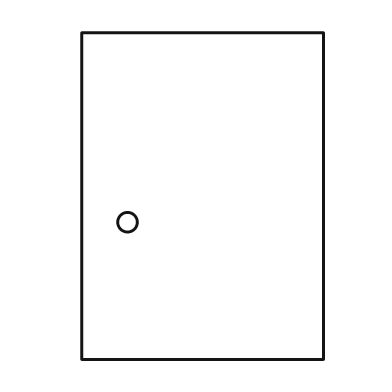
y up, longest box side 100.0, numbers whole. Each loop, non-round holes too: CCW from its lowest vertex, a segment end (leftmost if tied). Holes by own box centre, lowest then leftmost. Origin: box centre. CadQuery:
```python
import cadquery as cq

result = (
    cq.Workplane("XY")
    .moveTo(-37.0, -50.0)
    .lineTo(37.0, -50.0)
    .lineTo(37.0, 50.0)
    .lineTo(-37.0, 50.0)
    .close()
    .moveTo(-23.0, -8.0)
    .circle(3.0)
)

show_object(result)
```